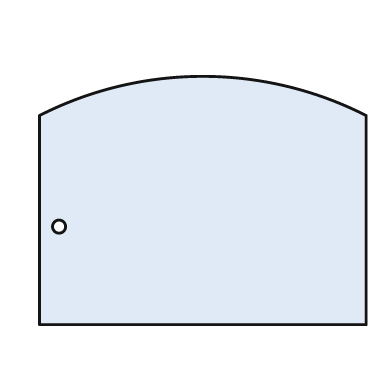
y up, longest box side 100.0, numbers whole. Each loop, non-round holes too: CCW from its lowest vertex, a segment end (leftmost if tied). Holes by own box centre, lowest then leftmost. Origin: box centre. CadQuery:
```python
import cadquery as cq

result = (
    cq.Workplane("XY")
    .moveTo(-50.0, -38.0)
    .lineTo(50.0, -38.0)
    .lineTo(50.0, 26.0)
    .threePointArc((0.0, 38.0), (-50.0, 26.0))
    .close()
    .moveTo(-44.0, -8.0)
    .circle(2.0)
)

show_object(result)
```